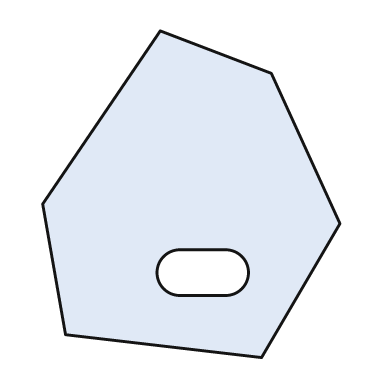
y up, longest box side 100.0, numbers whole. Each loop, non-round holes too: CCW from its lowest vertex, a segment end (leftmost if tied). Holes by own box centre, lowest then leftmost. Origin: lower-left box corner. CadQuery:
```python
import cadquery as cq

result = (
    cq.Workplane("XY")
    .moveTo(67.0, 0.0)
    .lineTo(91.0, 41.0)
    .lineTo(70.0, 87.0)
    .lineTo(36.0, 100.0)
    .lineTo(0.0, 47.0)
    .lineTo(7.0, 7.0)
    .close()
    .moveTo(42.0, 19.0)
    .lineTo(56.0, 19.0)
    .threePointArc((63.0, 26.0), (56.0, 33.0))
    .lineTo(42.0, 33.0)
    .threePointArc((35.0, 26.0), (42.0, 19.0))
    .close()
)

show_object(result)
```